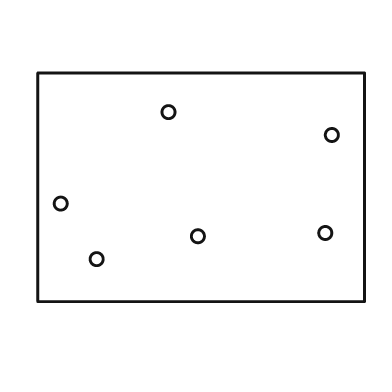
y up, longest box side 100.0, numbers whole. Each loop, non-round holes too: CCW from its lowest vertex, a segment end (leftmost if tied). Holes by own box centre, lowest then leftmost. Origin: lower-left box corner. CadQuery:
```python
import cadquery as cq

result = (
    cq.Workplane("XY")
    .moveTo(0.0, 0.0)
    .lineTo(100.0, 0.0)
    .lineTo(100.0, 70.0)
    .lineTo(0.0, 70.0)
    .close()
    .moveTo(18.0, 13.0)
    .circle(2.0)
    .moveTo(49.0, 20.0)
    .circle(2.0)
    .moveTo(88.0, 21.0)
    .circle(2.0)
    .moveTo(7.0, 30.0)
    .circle(2.0)
    .moveTo(90.0, 51.0)
    .circle(2.0)
    .moveTo(40.0, 58.0)
    .circle(2.0)
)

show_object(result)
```